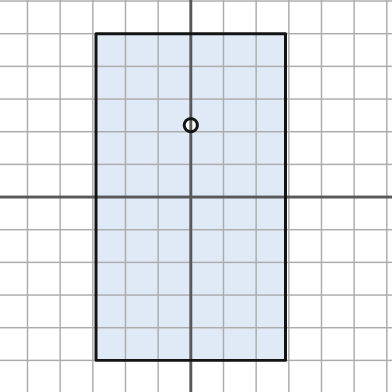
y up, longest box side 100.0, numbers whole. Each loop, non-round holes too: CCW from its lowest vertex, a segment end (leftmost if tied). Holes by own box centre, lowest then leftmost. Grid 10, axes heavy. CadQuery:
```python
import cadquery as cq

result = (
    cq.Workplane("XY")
    .moveTo(-29.0, -50.0)
    .lineTo(29.0, -50.0)
    .lineTo(29.0, 50.0)
    .lineTo(-29.0, 50.0)
    .close()
    .moveTo(0.0, 22.0)
    .circle(2.0)
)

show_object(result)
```